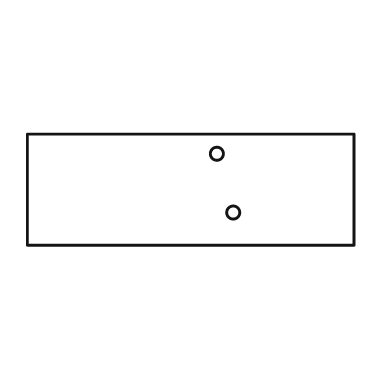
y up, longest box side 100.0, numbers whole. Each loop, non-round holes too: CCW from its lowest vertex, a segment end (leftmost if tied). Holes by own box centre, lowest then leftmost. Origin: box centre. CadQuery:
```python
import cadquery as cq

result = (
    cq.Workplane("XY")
    .moveTo(-50.0, -17.0)
    .lineTo(50.0, -17.0)
    .lineTo(50.0, 17.0)
    .lineTo(-50.0, 17.0)
    .close()
    .moveTo(13.0, -7.0)
    .circle(2.0)
    .moveTo(8.0, 11.0)
    .circle(2.0)
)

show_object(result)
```